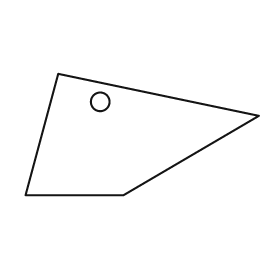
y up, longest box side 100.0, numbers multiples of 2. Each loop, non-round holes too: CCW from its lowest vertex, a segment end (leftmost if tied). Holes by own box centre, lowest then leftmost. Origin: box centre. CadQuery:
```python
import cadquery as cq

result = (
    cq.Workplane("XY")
    .moveTo(-50.0, -26.0)
    .lineTo(-8.0, -26.0)
    .lineTo(50.0, 8.0)
    .lineTo(-36.0, 26.0)
    .close()
    .moveTo(-18.0, 14.0)
    .circle(4.0)
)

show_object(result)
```